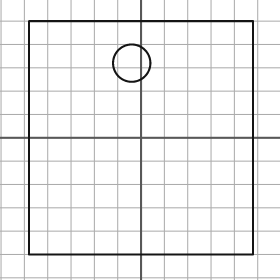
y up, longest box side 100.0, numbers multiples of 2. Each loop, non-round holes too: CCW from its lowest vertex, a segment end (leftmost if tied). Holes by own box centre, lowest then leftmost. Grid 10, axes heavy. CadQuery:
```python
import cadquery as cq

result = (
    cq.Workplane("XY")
    .moveTo(-48.0, -50.0)
    .lineTo(48.0, -50.0)
    .lineTo(48.0, 50.0)
    .lineTo(-48.0, 50.0)
    .close()
    .moveTo(-4.0, 32.0)
    .circle(8.0)
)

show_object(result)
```